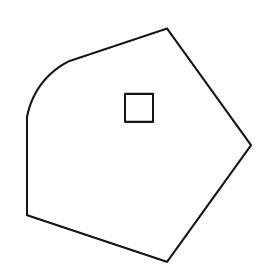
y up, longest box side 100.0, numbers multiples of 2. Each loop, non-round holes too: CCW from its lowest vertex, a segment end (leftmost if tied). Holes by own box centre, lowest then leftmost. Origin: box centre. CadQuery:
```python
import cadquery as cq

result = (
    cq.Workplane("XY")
    .moveTo(12.0, -50.0)
    .lineTo(48.0, 0.0)
    .lineTo(12.0, 50.0)
    .lineTo(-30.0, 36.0)
    .threePointArc((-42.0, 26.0), (-48.0, 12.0))
    .lineTo(-48.0, -30.0)
    .close()
    .moveTo(-6.0, 10.0)
    .lineTo(6.0, 10.0)
    .lineTo(6.0, 22.0)
    .lineTo(-6.0, 22.0)
    .close()
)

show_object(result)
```